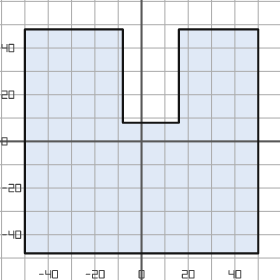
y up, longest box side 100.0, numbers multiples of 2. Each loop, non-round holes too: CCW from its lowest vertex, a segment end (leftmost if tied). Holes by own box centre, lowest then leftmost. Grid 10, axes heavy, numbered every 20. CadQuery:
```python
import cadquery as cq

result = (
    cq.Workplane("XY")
    .moveTo(-50.0, -48.0)
    .lineTo(50.0, -48.0)
    .lineTo(50.0, 48.0)
    .lineTo(16.0, 48.0)
    .lineTo(16.0, 8.0)
    .lineTo(-8.0, 8.0)
    .lineTo(-8.0, 48.0)
    .lineTo(-50.0, 48.0)
    .close()
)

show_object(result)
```